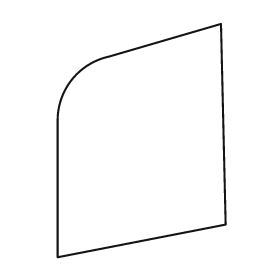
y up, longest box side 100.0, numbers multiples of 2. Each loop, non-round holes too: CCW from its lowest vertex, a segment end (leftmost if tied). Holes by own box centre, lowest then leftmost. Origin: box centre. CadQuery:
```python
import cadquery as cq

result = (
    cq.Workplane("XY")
    .moveTo(-36.0, -50.0)
    .lineTo(36.0, -36.0)
    .lineTo(34.0, 50.0)
    .lineTo(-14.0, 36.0)
    .threePointArc((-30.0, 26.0), (-36.0, 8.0))
    .close()
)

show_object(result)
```